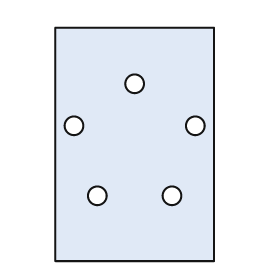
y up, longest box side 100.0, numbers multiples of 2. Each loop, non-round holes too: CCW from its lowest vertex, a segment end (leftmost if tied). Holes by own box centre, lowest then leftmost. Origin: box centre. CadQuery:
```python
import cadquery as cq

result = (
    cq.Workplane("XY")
    .moveTo(-34.0, -50.0)
    .lineTo(34.0, -50.0)
    .lineTo(34.0, 50.0)
    .lineTo(-34.0, 50.0)
    .close()
    .moveTo(-16.0, -22.0)
    .circle(4.0)
    .moveTo(16.0, -22.0)
    .circle(4.0)
    .moveTo(-26.0, 8.0)
    .circle(4.0)
    .moveTo(26.0, 8.0)
    .circle(4.0)
    .moveTo(0.0, 26.0)
    .circle(4.0)
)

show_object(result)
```